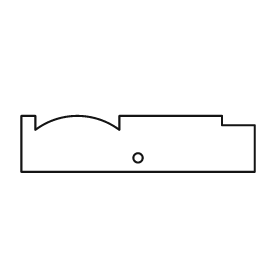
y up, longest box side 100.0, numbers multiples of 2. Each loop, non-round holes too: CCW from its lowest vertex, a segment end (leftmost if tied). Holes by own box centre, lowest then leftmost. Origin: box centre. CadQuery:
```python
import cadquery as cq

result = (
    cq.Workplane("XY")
    .moveTo(-50.0, -12.0)
    .lineTo(50.0, -12.0)
    .lineTo(50.0, 8.0)
    .lineTo(36.0, 8.0)
    .lineTo(36.0, 12.0)
    .lineTo(-8.0, 12.0)
    .lineTo(-8.0, 6.0)
    .threePointArc((-26.0, 12.0), (-44.0, 6.0))
    .lineTo(-44.0, 12.0)
    .lineTo(-50.0, 12.0)
    .close()
    .moveTo(0.0, -6.0)
    .circle(2.0)
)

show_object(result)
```